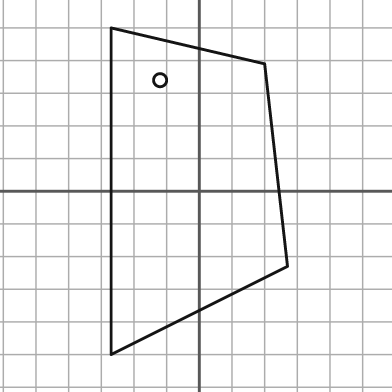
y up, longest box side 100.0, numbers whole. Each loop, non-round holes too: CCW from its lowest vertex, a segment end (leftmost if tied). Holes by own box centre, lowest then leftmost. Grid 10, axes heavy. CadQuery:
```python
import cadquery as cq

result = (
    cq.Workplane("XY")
    .moveTo(-27.0, -50.0)
    .lineTo(27.0, -23.0)
    .lineTo(20.0, 39.0)
    .lineTo(-27.0, 50.0)
    .close()
    .moveTo(-12.0, 34.0)
    .circle(2.0)
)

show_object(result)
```